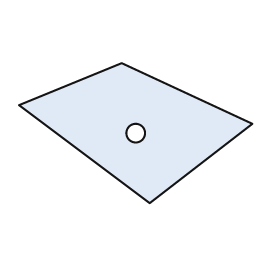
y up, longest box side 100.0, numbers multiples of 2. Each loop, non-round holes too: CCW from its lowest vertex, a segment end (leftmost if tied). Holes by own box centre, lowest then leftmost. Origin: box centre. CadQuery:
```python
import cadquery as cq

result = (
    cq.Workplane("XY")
    .moveTo(6.0, -30.0)
    .lineTo(50.0, 4.0)
    .lineTo(-6.0, 30.0)
    .lineTo(-50.0, 12.0)
    .close()
    .moveTo(0.0, 0.0)
    .circle(4.0)
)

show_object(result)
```